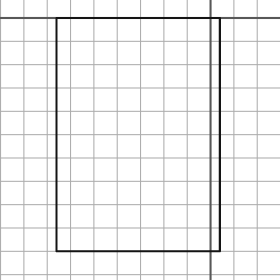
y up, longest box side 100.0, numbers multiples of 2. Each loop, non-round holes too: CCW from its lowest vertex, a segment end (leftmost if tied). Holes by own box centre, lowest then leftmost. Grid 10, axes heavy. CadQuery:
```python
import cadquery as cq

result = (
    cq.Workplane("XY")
    .moveTo(-66.0, -100.0)
    .lineTo(4.0, -100.0)
    .lineTo(4.0, 0.0)
    .lineTo(-66.0, 0.0)
    .close()
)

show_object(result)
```